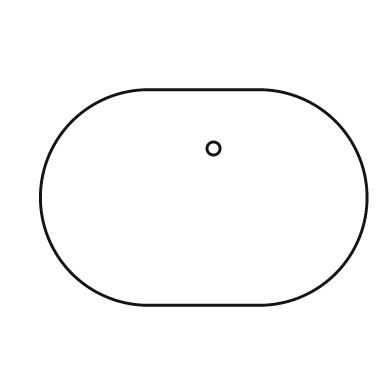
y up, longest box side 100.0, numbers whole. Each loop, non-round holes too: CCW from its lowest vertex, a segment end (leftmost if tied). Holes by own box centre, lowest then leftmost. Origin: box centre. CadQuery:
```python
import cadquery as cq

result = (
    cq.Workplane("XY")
    .moveTo(-17.0, -33.0)
    .lineTo(17.0, -33.0)
    .threePointArc((50.0, 0.0), (17.0, 33.0))
    .lineTo(-17.0, 33.0)
    .threePointArc((-50.0, 0.0), (-17.0, -33.0))
    .close()
    .moveTo(3.0, 15.0)
    .circle(2.0)
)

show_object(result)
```